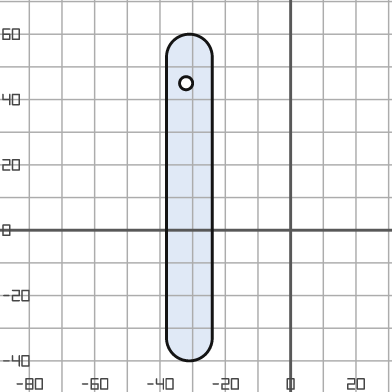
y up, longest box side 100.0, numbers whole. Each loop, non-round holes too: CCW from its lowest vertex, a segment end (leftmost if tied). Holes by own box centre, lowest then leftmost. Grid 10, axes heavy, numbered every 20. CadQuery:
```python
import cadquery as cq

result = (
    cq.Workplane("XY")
    .moveTo(-38.0, -33.0)
    .threePointArc((-31.0, -40.0), (-24.0, -33.0))
    .lineTo(-24.0, 53.0)
    .threePointArc((-31.0, 60.0), (-38.0, 53.0))
    .close()
    .moveTo(-32.0, 45.0)
    .circle(2.0)
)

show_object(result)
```